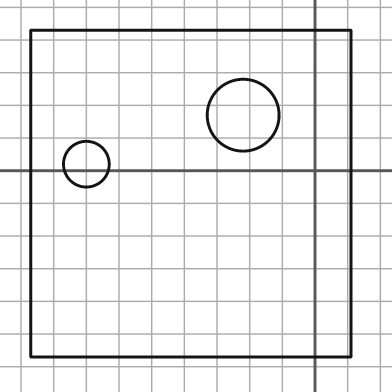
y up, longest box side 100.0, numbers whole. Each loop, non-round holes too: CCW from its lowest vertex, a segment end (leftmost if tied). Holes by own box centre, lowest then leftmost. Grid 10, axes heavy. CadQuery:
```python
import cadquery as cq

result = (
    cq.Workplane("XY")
    .moveTo(-87.0, -57.0)
    .lineTo(11.0, -57.0)
    .lineTo(11.0, 43.0)
    .lineTo(-87.0, 43.0)
    .close()
    .moveTo(-70.0, 2.0)
    .circle(7.0)
    .moveTo(-22.0, 17.0)
    .circle(11.0)
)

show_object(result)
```